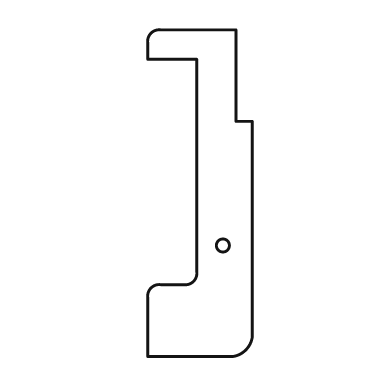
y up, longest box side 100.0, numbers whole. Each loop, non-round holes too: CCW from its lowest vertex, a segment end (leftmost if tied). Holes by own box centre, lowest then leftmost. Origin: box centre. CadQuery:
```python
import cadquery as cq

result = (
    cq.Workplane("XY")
    .moveTo(-16.0, -50.0)
    .lineTo(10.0, -50.0)
    .threePointArc((14.0, -48.0), (16.0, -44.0))
    .lineTo(16.0, 22.0)
    .lineTo(11.0, 22.0)
    .lineTo(11.0, 50.0)
    .lineTo(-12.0, 50.0)
    .threePointArc((-15.0, 49.0), (-16.0, 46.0))
    .lineTo(-16.0, 41.0)
    .lineTo(-1.0, 41.0)
    .lineTo(-1.0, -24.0)
    .threePointArc((-2.0, -27.0), (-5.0, -28.0))
    .lineTo(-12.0, -28.0)
    .threePointArc((-15.0, -29.0), (-16.0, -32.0))
    .close()
    .moveTo(7.0, -16.0)
    .circle(2.0)
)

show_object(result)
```